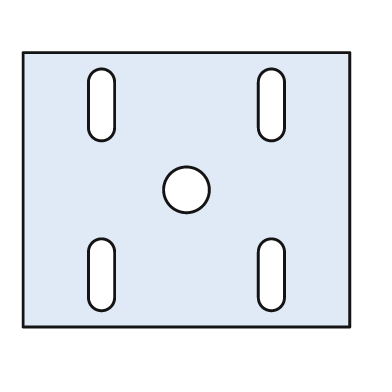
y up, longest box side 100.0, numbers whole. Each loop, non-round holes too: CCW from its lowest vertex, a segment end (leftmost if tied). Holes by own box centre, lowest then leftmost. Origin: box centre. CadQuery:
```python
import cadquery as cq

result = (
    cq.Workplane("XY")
    .moveTo(-50.0, -42.0)
    .lineTo(50.0, -42.0)
    .lineTo(50.0, 42.0)
    .lineTo(-50.0, 42.0)
    .close()
    .moveTo(-30.0, -33.0)
    .threePointArc((-26.0, -37.0), (-22.0, -33.0))
    .lineTo(-22.0, -19.0)
    .threePointArc((-26.0, -15.0), (-30.0, -19.0))
    .close()
    .moveTo(22.0, -33.0)
    .threePointArc((26.0, -37.0), (30.0, -33.0))
    .lineTo(30.0, -19.0)
    .threePointArc((26.0, -15.0), (22.0, -19.0))
    .close()
    .moveTo(0.0, 0.0)
    .circle(7.0)
    .moveTo(-30.0, 19.0)
    .threePointArc((-26.0, 15.0), (-22.0, 19.0))
    .lineTo(-22.0, 33.0)
    .threePointArc((-26.0, 37.0), (-30.0, 33.0))
    .close()
    .moveTo(22.0, 19.0)
    .threePointArc((26.0, 15.0), (30.0, 19.0))
    .lineTo(30.0, 33.0)
    .threePointArc((26.0, 37.0), (22.0, 33.0))
    .close()
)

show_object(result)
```